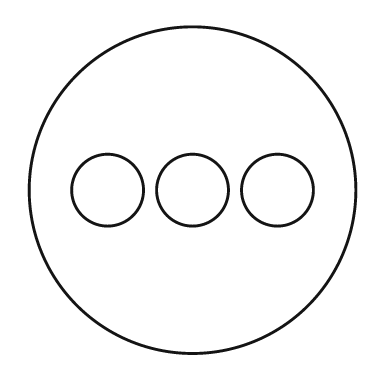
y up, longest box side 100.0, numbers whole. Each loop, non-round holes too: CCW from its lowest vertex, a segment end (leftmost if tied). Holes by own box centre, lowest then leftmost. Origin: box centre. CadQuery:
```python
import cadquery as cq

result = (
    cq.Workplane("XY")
    .moveTo(0.0, 0.0)
    .circle(50.0)
    .moveTo(-26.0, 0.0)
    .circle(11.0)
    .moveTo(0.0, 0.0)
    .circle(11.0)
    .moveTo(26.0, 0.0)
    .circle(11.0)
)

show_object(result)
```